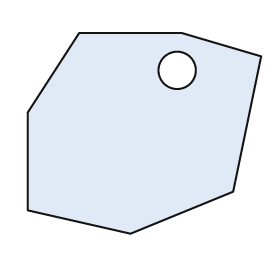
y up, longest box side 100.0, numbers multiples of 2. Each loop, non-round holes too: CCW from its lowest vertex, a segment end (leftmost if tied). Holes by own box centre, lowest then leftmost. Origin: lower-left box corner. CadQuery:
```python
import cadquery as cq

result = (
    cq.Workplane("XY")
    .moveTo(44.0, 0.0)
    .lineTo(88.0, 18.0)
    .lineTo(100.0, 76.0)
    .lineTo(66.0, 86.0)
    .lineTo(22.0, 86.0)
    .lineTo(0.0, 52.0)
    .lineTo(0.0, 10.0)
    .close()
    .moveTo(64.0, 70.0)
    .circle(8.0)
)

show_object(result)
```